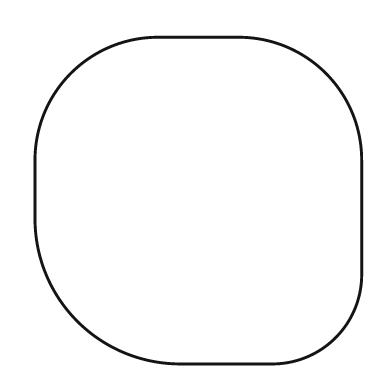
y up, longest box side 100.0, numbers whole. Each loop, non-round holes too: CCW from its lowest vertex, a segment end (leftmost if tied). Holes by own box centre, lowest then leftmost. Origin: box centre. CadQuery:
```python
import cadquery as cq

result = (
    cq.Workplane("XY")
    .moveTo(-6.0, -50.0)
    .lineTo(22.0, -50.0)
    .threePointArc((42.0, -42.0), (50.0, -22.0))
    .lineTo(50.0, 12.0)
    .threePointArc((39.0, 39.0), (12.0, 50.0))
    .lineTo(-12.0, 50.0)
    .threePointArc((-39.0, 39.0), (-50.0, 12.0))
    .lineTo(-50.0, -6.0)
    .threePointArc((-37.0, -37.0), (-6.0, -50.0))
    .close()
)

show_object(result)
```